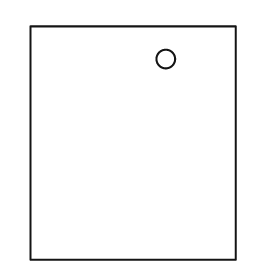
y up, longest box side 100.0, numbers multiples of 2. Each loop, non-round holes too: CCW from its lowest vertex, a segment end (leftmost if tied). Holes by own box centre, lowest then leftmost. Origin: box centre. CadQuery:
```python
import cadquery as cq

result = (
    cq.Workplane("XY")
    .moveTo(-44.0, -50.0)
    .lineTo(44.0, -50.0)
    .lineTo(44.0, 50.0)
    .lineTo(-44.0, 50.0)
    .close()
    .moveTo(14.0, 36.0)
    .circle(4.0)
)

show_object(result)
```